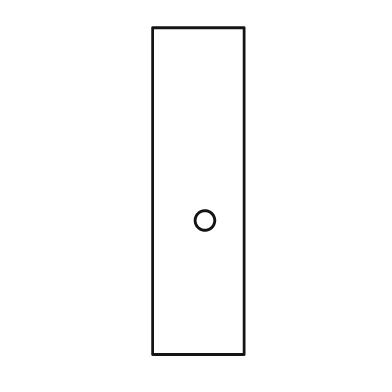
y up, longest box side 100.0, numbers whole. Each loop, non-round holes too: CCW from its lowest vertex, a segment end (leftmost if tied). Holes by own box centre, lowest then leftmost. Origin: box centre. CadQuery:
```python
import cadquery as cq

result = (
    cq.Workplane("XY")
    .moveTo(-14.0, -50.0)
    .lineTo(14.0, -50.0)
    .lineTo(14.0, 50.0)
    .lineTo(-14.0, 50.0)
    .close()
    .moveTo(2.0, -9.0)
    .circle(3.0)
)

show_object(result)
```